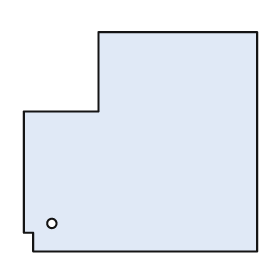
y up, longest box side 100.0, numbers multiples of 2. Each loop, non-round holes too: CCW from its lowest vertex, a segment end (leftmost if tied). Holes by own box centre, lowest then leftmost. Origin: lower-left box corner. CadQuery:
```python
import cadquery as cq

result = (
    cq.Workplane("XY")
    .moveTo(4.0, 0.0)
    .lineTo(100.0, 0.0)
    .lineTo(100.0, 94.0)
    .lineTo(32.0, 94.0)
    .lineTo(32.0, 60.0)
    .lineTo(0.0, 60.0)
    .lineTo(0.0, 8.0)
    .lineTo(4.0, 8.0)
    .close()
    .moveTo(12.0, 12.0)
    .circle(2.0)
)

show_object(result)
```